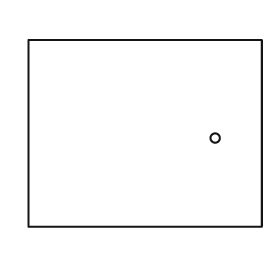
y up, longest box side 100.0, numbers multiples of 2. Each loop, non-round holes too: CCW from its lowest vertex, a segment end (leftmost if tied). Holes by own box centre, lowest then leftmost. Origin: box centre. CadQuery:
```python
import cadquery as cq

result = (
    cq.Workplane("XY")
    .moveTo(-50.0, -40.0)
    .lineTo(50.0, -40.0)
    .lineTo(50.0, 40.0)
    .lineTo(-50.0, 40.0)
    .close()
    .moveTo(30.0, -2.0)
    .circle(2.0)
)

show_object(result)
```